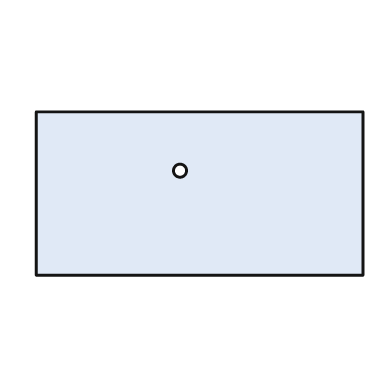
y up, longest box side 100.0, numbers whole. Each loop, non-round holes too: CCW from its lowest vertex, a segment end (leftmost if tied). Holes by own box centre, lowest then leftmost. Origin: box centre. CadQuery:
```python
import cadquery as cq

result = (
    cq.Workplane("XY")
    .moveTo(-50.0, -25.0)
    .lineTo(50.0, -25.0)
    .lineTo(50.0, 25.0)
    .lineTo(-50.0, 25.0)
    .close()
    .moveTo(-6.0, 7.0)
    .circle(2.0)
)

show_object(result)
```